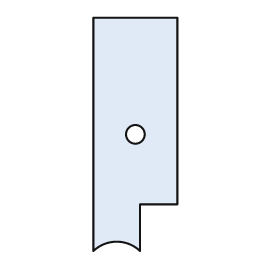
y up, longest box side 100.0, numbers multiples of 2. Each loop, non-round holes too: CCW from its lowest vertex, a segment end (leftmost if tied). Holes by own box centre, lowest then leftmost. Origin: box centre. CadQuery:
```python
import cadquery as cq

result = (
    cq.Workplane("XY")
    .moveTo(-18.0, -50.0)
    .threePointArc((-8.0, -46.0), (2.0, -50.0))
    .lineTo(2.0, -30.0)
    .lineTo(18.0, -30.0)
    .lineTo(18.0, 50.0)
    .lineTo(-18.0, 50.0)
    .close()
    .moveTo(0.0, 0.0)
    .circle(4.0)
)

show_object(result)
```